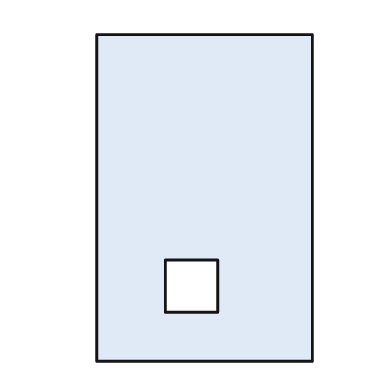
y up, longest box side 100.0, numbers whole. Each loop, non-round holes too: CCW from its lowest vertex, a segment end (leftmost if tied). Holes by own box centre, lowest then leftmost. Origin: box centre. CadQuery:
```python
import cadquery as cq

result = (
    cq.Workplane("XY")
    .moveTo(-33.0, -50.0)
    .lineTo(33.0, -50.0)
    .lineTo(33.0, 50.0)
    .lineTo(-33.0, 50.0)
    .close()
    .moveTo(-12.0, -35.0)
    .lineTo(4.0, -35.0)
    .lineTo(4.0, -19.0)
    .lineTo(-12.0, -19.0)
    .close()
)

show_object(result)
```